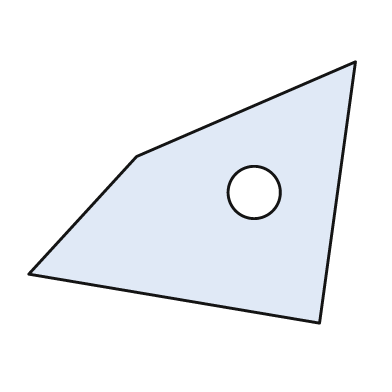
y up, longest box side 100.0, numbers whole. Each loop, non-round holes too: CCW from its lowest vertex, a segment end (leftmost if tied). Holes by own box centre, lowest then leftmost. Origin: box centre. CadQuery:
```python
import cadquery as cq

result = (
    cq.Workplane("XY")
    .moveTo(39.0, -40.0)
    .lineTo(50.0, 40.0)
    .lineTo(-17.0, 11.0)
    .lineTo(-50.0, -25.0)
    .close()
    .moveTo(19.0, 0.0)
    .circle(8.0)
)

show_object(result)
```